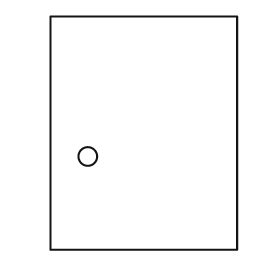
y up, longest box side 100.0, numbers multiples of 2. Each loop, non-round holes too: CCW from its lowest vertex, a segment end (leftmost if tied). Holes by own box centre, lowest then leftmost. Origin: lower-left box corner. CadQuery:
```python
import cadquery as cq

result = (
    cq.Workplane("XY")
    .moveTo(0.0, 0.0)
    .lineTo(80.0, 0.0)
    .lineTo(80.0, 100.0)
    .lineTo(0.0, 100.0)
    .close()
    .moveTo(16.0, 40.0)
    .circle(4.0)
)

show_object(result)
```